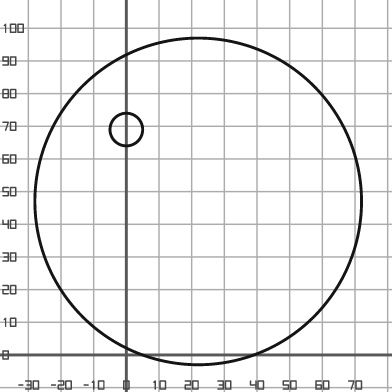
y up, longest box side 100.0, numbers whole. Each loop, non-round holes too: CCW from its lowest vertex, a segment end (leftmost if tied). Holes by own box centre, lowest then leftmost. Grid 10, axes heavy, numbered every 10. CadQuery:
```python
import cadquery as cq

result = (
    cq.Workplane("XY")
    .moveTo(22.0, 47.0)
    .circle(50.0)
    .moveTo(0.0, 69.0)
    .circle(5.0)
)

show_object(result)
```